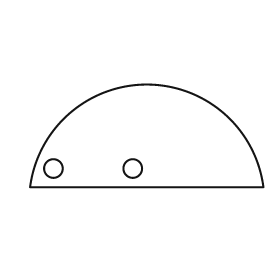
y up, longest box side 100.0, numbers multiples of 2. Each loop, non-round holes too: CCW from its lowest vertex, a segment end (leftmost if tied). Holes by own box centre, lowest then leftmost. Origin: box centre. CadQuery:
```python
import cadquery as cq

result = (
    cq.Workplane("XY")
    .moveTo(-50.0, -22.0)
    .lineTo(50.0, -22.0)
    .threePointArc((0.0, 22.0), (-50.0, -22.0))
    .close()
    .moveTo(-40.0, -14.0)
    .circle(4.0)
    .moveTo(-6.0, -14.0)
    .circle(4.0)
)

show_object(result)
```